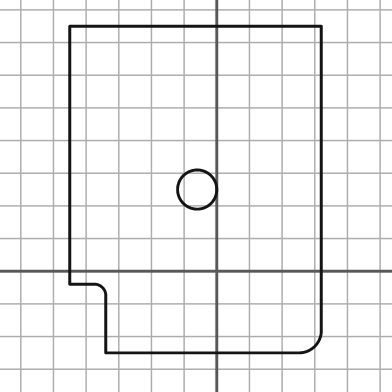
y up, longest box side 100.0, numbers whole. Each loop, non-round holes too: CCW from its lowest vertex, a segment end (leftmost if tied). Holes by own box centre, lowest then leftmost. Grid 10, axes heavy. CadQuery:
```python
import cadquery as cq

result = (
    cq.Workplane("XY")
    .moveTo(-34.0, -25.0)
    .lineTo(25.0, -25.0)
    .threePointArc((30.0, -23.0), (32.0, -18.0))
    .lineTo(32.0, 75.0)
    .lineTo(-45.0, 75.0)
    .lineTo(-45.0, -4.0)
    .lineTo(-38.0, -4.0)
    .threePointArc((-35.0, -5.0), (-34.0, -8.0))
    .close()
    .moveTo(-6.0, 25.0)
    .circle(6.0)
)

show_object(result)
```